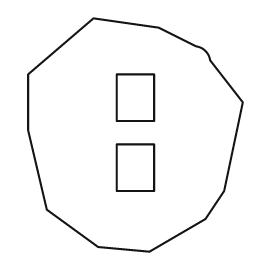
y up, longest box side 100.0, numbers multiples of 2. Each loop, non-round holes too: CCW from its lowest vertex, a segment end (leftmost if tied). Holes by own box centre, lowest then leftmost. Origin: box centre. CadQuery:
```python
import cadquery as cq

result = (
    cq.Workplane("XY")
    .moveTo(6.0, -50.0)
    .lineTo(30.0, -36.0)
    .lineTo(38.0, -24.0)
    .lineTo(46.0, 14.0)
    .lineTo(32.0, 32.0)
    .threePointArc((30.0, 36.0), (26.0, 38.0))
    .lineTo(10.0, 46.0)
    .lineTo(-18.0, 50.0)
    .lineTo(-46.0, 26.0)
    .lineTo(-46.0, 2.0)
    .lineTo(-38.0, -32.0)
    .lineTo(-16.0, -48.0)
    .close()
    .moveTo(-8.0, -24.0)
    .lineTo(8.0, -24.0)
    .lineTo(8.0, -4.0)
    .lineTo(-8.0, -4.0)
    .close()
    .moveTo(-8.0, 6.0)
    .lineTo(8.0, 6.0)
    .lineTo(8.0, 26.0)
    .lineTo(-8.0, 26.0)
    .close()
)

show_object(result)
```